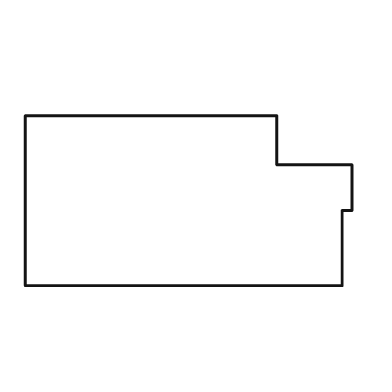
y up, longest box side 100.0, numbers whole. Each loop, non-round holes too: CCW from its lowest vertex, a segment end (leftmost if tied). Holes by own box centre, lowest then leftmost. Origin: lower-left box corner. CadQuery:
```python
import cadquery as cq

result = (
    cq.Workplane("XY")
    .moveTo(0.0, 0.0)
    .lineTo(97.0, 0.0)
    .lineTo(97.0, 23.0)
    .lineTo(100.0, 23.0)
    .lineTo(100.0, 37.0)
    .lineTo(77.0, 37.0)
    .lineTo(77.0, 52.0)
    .lineTo(0.0, 52.0)
    .close()
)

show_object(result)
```